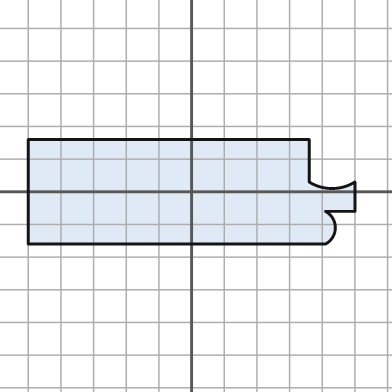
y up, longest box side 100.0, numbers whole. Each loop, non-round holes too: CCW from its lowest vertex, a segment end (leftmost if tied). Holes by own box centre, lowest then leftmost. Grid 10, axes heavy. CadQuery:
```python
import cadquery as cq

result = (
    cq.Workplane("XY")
    .moveTo(-50.0, -16.0)
    .lineTo(41.0, -16.0)
    .threePointArc((44.0, -11.0), (41.0, -6.0))
    .lineTo(50.0, -6.0)
    .lineTo(50.0, 3.0)
    .threePointArc((43.0, 1.0), (36.0, 3.0))
    .lineTo(36.0, 16.0)
    .lineTo(-50.0, 16.0)
    .close()
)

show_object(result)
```